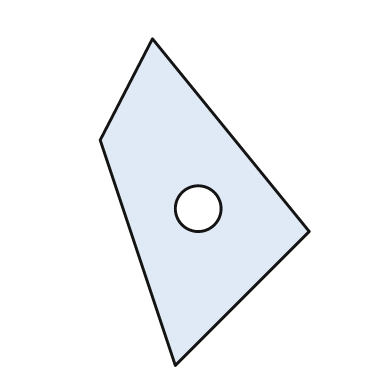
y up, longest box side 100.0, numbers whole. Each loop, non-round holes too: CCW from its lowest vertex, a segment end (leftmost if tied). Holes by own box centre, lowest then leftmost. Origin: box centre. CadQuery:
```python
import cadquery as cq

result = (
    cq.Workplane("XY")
    .moveTo(-9.0, -50.0)
    .lineTo(32.0, -9.0)
    .lineTo(-16.0, 50.0)
    .lineTo(-32.0, 19.0)
    .close()
    .moveTo(-2.0, -2.0)
    .circle(7.0)
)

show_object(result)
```